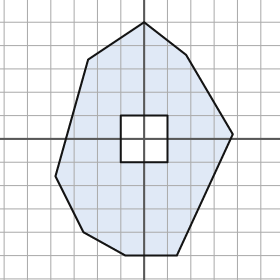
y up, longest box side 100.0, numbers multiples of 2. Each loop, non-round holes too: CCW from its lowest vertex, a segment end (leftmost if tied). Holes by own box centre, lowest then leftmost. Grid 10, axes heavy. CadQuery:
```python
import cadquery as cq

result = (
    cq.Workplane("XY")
    .moveTo(-8.0, -50.0)
    .lineTo(14.0, -50.0)
    .lineTo(38.0, 2.0)
    .lineTo(18.0, 36.0)
    .lineTo(0.0, 50.0)
    .lineTo(-24.0, 34.0)
    .lineTo(-38.0, -16.0)
    .lineTo(-26.0, -40.0)
    .close()
    .moveTo(-10.0, -10.0)
    .lineTo(10.0, -10.0)
    .lineTo(10.0, 10.0)
    .lineTo(-10.0, 10.0)
    .close()
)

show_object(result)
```